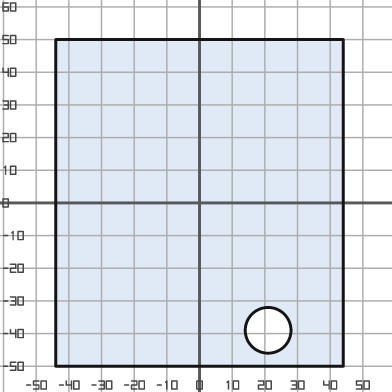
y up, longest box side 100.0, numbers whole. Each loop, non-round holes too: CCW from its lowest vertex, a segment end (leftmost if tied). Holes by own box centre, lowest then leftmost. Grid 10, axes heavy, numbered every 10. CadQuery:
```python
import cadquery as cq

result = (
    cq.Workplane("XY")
    .moveTo(-44.0, -50.0)
    .lineTo(44.0, -50.0)
    .lineTo(44.0, 50.0)
    .lineTo(-44.0, 50.0)
    .close()
    .moveTo(21.0, -39.0)
    .circle(7.0)
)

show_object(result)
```